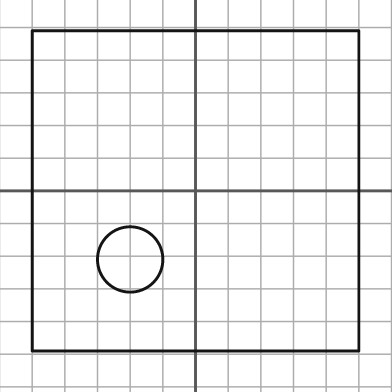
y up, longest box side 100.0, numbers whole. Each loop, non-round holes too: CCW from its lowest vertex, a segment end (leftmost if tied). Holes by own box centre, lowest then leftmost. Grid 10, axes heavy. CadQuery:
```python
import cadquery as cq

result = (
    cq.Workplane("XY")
    .moveTo(-50.0, -49.0)
    .lineTo(50.0, -49.0)
    .lineTo(50.0, 49.0)
    .lineTo(-50.0, 49.0)
    .close()
    .moveTo(-20.0, -21.0)
    .circle(10.0)
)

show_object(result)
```